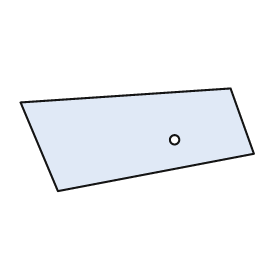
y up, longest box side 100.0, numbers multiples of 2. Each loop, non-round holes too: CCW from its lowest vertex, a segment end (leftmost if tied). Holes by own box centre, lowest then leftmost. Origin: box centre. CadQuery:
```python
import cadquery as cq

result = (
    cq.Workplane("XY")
    .moveTo(-34.0, -22.0)
    .lineTo(50.0, -6.0)
    .lineTo(40.0, 22.0)
    .lineTo(-50.0, 16.0)
    .close()
    .moveTo(16.0, 0.0)
    .circle(2.0)
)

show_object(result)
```